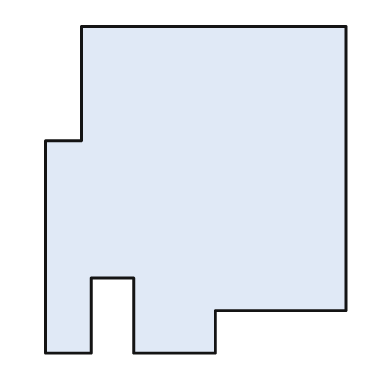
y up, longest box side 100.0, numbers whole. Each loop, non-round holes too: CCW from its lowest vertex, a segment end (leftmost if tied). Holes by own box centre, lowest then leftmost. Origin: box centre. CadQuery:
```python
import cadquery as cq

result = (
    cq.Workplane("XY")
    .moveTo(-46.0, -50.0)
    .lineTo(-32.0, -50.0)
    .lineTo(-32.0, -27.0)
    .lineTo(-19.0, -27.0)
    .lineTo(-19.0, -50.0)
    .lineTo(6.0, -50.0)
    .lineTo(6.0, -37.0)
    .lineTo(46.0, -37.0)
    .lineTo(46.0, 50.0)
    .lineTo(-35.0, 50.0)
    .lineTo(-35.0, 15.0)
    .lineTo(-46.0, 15.0)
    .close()
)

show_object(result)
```